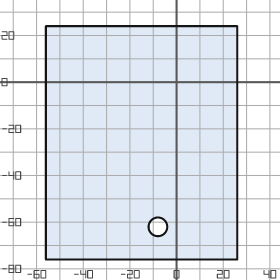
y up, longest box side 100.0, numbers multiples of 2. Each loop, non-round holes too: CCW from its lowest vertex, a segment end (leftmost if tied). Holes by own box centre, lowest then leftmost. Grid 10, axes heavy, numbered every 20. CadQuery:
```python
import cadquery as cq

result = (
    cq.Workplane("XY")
    .moveTo(-56.0, -76.0)
    .lineTo(26.0, -76.0)
    .lineTo(26.0, 24.0)
    .lineTo(-56.0, 24.0)
    .close()
    .moveTo(-8.0, -62.0)
    .circle(4.0)
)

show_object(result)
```